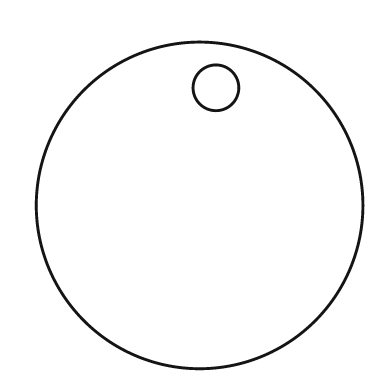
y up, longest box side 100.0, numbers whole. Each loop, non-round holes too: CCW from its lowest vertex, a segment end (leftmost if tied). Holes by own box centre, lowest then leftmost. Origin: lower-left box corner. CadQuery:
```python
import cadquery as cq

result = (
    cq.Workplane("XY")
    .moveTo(50.0, 50.0)
    .circle(50.0)
    .moveTo(55.0, 86.0)
    .circle(7.0)
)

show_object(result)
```